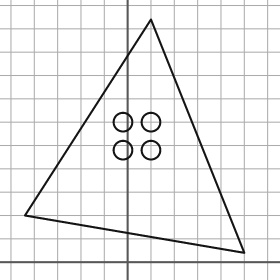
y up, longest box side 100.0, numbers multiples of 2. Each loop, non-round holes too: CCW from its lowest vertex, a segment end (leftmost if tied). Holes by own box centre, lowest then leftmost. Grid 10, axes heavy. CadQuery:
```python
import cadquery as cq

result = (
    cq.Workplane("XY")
    .moveTo(50.0, 4.0)
    .lineTo(10.0, 104.0)
    .lineTo(-44.0, 20.0)
    .close()
    .moveTo(-2.0, 48.0)
    .circle(4.0)
    .moveTo(10.0, 48.0)
    .circle(4.0)
    .moveTo(-2.0, 60.0)
    .circle(4.0)
    .moveTo(10.0, 60.0)
    .circle(4.0)
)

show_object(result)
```